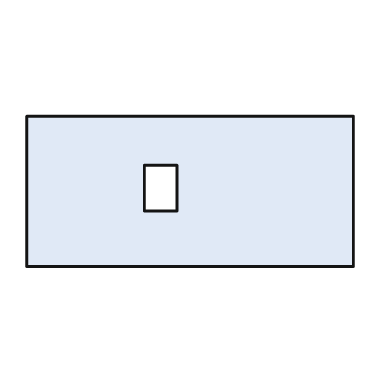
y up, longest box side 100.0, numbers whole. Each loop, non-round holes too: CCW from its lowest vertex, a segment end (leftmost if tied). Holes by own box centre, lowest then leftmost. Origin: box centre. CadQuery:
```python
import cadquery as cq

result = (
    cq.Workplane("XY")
    .moveTo(-50.0, -23.0)
    .lineTo(50.0, -23.0)
    .lineTo(50.0, 23.0)
    .lineTo(-50.0, 23.0)
    .close()
    .moveTo(-14.0, -6.0)
    .lineTo(-4.0, -6.0)
    .lineTo(-4.0, 8.0)
    .lineTo(-14.0, 8.0)
    .close()
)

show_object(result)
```